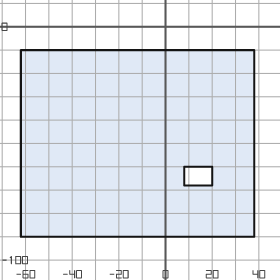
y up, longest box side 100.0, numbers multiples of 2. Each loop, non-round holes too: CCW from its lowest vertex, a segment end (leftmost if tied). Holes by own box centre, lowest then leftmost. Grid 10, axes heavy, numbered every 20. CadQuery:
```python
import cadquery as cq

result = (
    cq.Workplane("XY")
    .moveTo(-62.0, -90.0)
    .lineTo(38.0, -90.0)
    .lineTo(38.0, -10.0)
    .lineTo(-62.0, -10.0)
    .close()
    .moveTo(8.0, -68.0)
    .lineTo(20.0, -68.0)
    .lineTo(20.0, -60.0)
    .lineTo(8.0, -60.0)
    .close()
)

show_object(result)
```